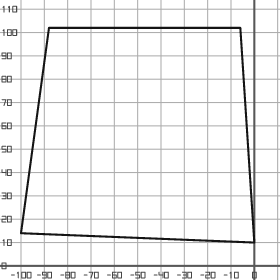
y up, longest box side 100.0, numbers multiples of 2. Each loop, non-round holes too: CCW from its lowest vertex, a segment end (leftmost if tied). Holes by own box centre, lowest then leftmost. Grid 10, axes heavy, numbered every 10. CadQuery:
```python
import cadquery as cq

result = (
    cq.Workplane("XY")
    .moveTo(0.0, 10.0)
    .lineTo(-6.0, 102.0)
    .lineTo(-88.0, 102.0)
    .lineTo(-100.0, 14.0)
    .close()
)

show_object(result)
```